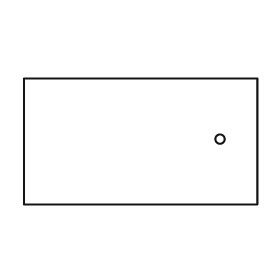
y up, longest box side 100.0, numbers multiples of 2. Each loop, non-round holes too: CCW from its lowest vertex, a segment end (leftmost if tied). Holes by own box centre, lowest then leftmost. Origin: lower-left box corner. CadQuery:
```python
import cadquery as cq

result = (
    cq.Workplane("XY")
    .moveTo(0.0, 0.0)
    .lineTo(100.0, 0.0)
    .lineTo(100.0, 54.0)
    .lineTo(0.0, 54.0)
    .close()
    .moveTo(84.0, 28.0)
    .circle(2.0)
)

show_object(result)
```